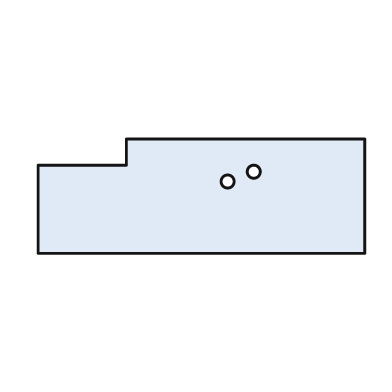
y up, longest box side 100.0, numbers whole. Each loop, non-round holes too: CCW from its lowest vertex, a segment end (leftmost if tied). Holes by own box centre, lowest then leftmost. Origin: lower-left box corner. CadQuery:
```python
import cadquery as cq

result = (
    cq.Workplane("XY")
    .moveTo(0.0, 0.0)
    .lineTo(100.0, 0.0)
    .lineTo(100.0, 35.0)
    .lineTo(27.0, 35.0)
    .lineTo(27.0, 27.0)
    .lineTo(0.0, 27.0)
    .close()
    .moveTo(58.0, 22.0)
    .circle(2.0)
    .moveTo(66.0, 25.0)
    .circle(2.0)
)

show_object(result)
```